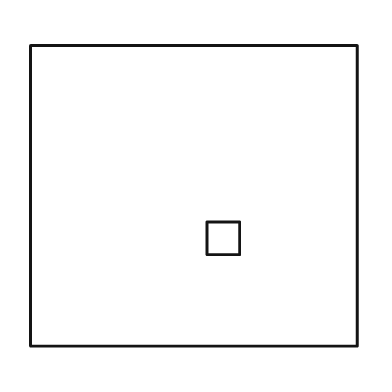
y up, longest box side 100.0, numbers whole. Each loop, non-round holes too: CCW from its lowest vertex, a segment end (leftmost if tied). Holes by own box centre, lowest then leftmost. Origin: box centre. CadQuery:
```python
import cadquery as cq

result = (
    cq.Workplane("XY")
    .moveTo(-50.0, -46.0)
    .lineTo(50.0, -46.0)
    .lineTo(50.0, 46.0)
    .lineTo(-50.0, 46.0)
    .close()
    .moveTo(4.0, -18.0)
    .lineTo(14.0, -18.0)
    .lineTo(14.0, -8.0)
    .lineTo(4.0, -8.0)
    .close()
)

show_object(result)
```